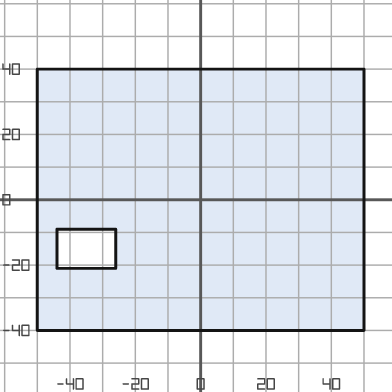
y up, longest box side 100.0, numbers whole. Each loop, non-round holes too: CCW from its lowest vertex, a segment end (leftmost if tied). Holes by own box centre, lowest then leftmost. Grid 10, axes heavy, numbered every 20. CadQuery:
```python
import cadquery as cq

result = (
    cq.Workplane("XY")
    .moveTo(-50.0, -40.0)
    .lineTo(50.0, -40.0)
    .lineTo(50.0, 40.0)
    .lineTo(-50.0, 40.0)
    .close()
    .moveTo(-44.0, -21.0)
    .lineTo(-26.0, -21.0)
    .lineTo(-26.0, -9.0)
    .lineTo(-44.0, -9.0)
    .close()
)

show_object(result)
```